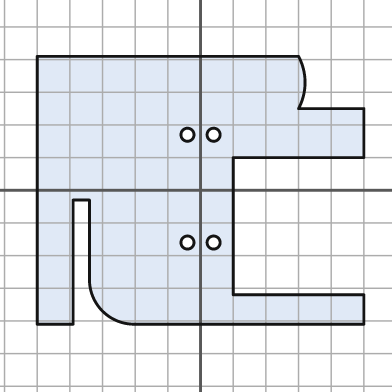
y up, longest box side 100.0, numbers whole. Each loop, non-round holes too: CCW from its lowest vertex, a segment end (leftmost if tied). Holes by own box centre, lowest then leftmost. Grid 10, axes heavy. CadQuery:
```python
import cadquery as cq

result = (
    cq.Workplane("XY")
    .moveTo(-50.0, -41.0)
    .lineTo(-39.0, -41.0)
    .lineTo(-39.0, -3.0)
    .lineTo(-34.0, -3.0)
    .lineTo(-34.0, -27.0)
    .threePointArc((-30.0, -37.0), (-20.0, -41.0))
    .lineTo(50.0, -41.0)
    .lineTo(50.0, -32.0)
    .lineTo(10.0, -32.0)
    .lineTo(10.0, 10.0)
    .lineTo(50.0, 10.0)
    .lineTo(50.0, 25.0)
    .lineTo(30.0, 25.0)
    .threePointArc((32.0, 33.0), (30.0, 41.0))
    .lineTo(-50.0, 41.0)
    .close()
    .moveTo(-4.0, -16.0)
    .circle(2.0)
    .moveTo(4.0, -16.0)
    .circle(2.0)
    .moveTo(-4.0, 17.0)
    .circle(2.0)
    .moveTo(4.0, 17.0)
    .circle(2.0)
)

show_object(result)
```